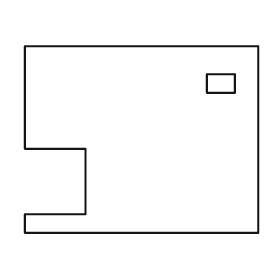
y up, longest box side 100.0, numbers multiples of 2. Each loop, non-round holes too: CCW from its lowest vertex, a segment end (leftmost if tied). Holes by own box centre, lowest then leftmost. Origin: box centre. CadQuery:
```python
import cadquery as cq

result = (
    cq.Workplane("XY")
    .moveTo(-50.0, -40.0)
    .lineTo(50.0, -40.0)
    .lineTo(50.0, 40.0)
    .lineTo(-50.0, 40.0)
    .lineTo(-50.0, -4.0)
    .lineTo(-24.0, -4.0)
    .lineTo(-24.0, -32.0)
    .lineTo(-50.0, -32.0)
    .close()
    .moveTo(28.0, 20.0)
    .lineTo(40.0, 20.0)
    .lineTo(40.0, 28.0)
    .lineTo(28.0, 28.0)
    .close()
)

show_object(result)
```